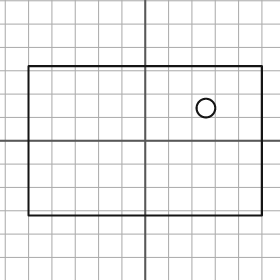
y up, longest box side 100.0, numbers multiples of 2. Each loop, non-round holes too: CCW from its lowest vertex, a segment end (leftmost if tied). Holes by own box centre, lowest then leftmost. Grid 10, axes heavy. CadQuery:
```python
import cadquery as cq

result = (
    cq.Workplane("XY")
    .moveTo(-50.0, -32.0)
    .lineTo(50.0, -32.0)
    .lineTo(50.0, 32.0)
    .lineTo(-50.0, 32.0)
    .close()
    .moveTo(26.0, 14.0)
    .circle(4.0)
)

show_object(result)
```